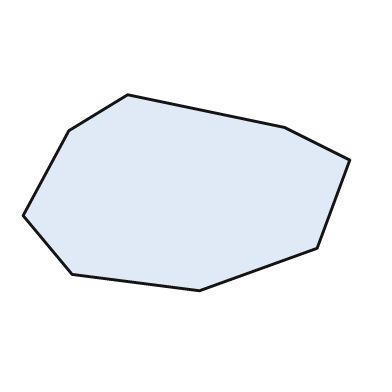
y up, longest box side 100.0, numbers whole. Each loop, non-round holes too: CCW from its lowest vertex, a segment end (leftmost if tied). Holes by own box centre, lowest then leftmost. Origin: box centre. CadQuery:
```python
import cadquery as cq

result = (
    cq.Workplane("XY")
    .moveTo(4.0, -30.0)
    .lineTo(40.0, -17.0)
    .lineTo(50.0, 10.0)
    .lineTo(30.0, 20.0)
    .lineTo(-18.0, 30.0)
    .lineTo(-36.0, 19.0)
    .lineTo(-50.0, -7.0)
    .lineTo(-35.0, -25.0)
    .close()
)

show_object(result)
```